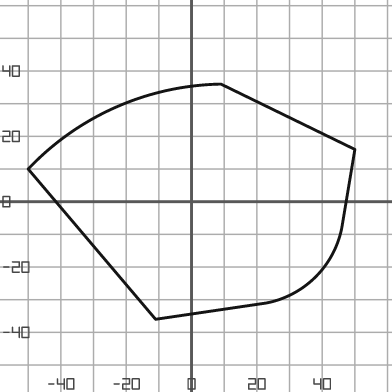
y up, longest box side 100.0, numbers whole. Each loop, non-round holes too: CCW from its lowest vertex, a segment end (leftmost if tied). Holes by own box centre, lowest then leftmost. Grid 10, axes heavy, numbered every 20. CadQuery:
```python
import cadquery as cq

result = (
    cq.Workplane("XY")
    .moveTo(-11.0, -36.0)
    .lineTo(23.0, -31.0)
    .threePointArc((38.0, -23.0), (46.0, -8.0))
    .lineTo(50.0, 16.0)
    .lineTo(9.0, 36.0)
    .threePointArc((-23.0, 29.0), (-50.0, 10.0))
    .close()
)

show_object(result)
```